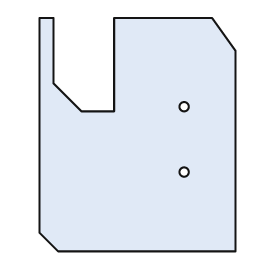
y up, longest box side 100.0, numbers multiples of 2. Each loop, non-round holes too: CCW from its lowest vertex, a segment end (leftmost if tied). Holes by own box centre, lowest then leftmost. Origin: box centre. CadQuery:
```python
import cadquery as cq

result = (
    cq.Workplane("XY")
    .moveTo(-34.0, -50.0)
    .lineTo(42.0, -50.0)
    .lineTo(42.0, 36.0)
    .lineTo(32.0, 50.0)
    .lineTo(-10.0, 50.0)
    .lineTo(-10.0, 10.0)
    .lineTo(-24.0, 10.0)
    .lineTo(-36.0, 22.0)
    .lineTo(-36.0, 50.0)
    .lineTo(-42.0, 50.0)
    .lineTo(-42.0, -42.0)
    .close()
    .moveTo(20.0, -16.0)
    .circle(2.0)
    .moveTo(20.0, 12.0)
    .circle(2.0)
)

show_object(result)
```